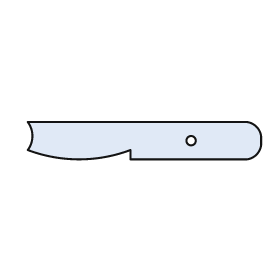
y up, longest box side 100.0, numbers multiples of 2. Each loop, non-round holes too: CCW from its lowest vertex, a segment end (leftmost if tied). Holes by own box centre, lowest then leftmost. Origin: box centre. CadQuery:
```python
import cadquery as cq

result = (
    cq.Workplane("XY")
    .moveTo(-6.0, -8.0)
    .lineTo(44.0, -8.0)
    .threePointArc((48.0, -6.0), (50.0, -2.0))
    .lineTo(50.0, 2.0)
    .threePointArc((48.0, 6.0), (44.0, 8.0))
    .lineTo(-50.0, 8.0)
    .threePointArc((-48.0, 2.0), (-50.0, -4.0))
    .threePointArc((-28.0, -8.0), (-6.0, -4.0))
    .close()
    .moveTo(20.0, 0.0)
    .circle(2.0)
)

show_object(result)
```